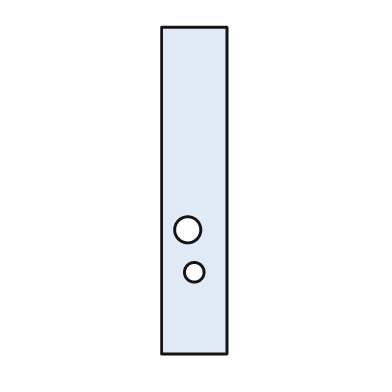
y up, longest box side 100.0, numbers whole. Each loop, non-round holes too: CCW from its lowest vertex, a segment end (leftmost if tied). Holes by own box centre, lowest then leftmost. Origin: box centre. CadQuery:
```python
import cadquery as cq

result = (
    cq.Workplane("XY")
    .moveTo(-10.0, -50.0)
    .lineTo(10.0, -50.0)
    .lineTo(10.0, 50.0)
    .lineTo(-10.0, 50.0)
    .close()
    .moveTo(0.0, -25.0)
    .circle(3.0)
    .moveTo(-2.0, -12.0)
    .circle(4.0)
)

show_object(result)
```